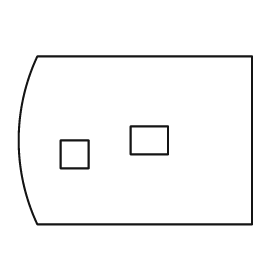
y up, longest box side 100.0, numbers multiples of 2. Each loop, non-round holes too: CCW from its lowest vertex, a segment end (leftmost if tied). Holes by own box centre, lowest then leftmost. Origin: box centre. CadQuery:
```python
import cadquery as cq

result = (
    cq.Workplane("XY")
    .moveTo(-42.0, -36.0)
    .lineTo(50.0, -36.0)
    .lineTo(50.0, 36.0)
    .lineTo(-42.0, 36.0)
    .threePointArc((-50.0, 0.0), (-42.0, -36.0))
    .close()
    .moveTo(-32.0, -12.0)
    .lineTo(-20.0, -12.0)
    .lineTo(-20.0, 0.0)
    .lineTo(-32.0, 0.0)
    .close()
    .moveTo(-2.0, -6.0)
    .lineTo(14.0, -6.0)
    .lineTo(14.0, 6.0)
    .lineTo(-2.0, 6.0)
    .close()
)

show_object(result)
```